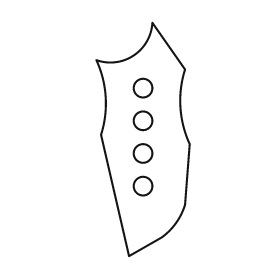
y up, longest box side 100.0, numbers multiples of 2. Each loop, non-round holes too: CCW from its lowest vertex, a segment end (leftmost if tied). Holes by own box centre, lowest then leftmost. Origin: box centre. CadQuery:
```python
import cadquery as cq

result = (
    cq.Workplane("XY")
    .moveTo(-6.0, -50.0)
    .lineTo(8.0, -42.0)
    .threePointArc((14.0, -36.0), (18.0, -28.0))
    .lineTo(20.0, -2.0)
    .threePointArc((16.0, 14.0), (18.0, 30.0))
    .lineTo(4.0, 50.0)
    .threePointArc((-4.0, 36.0), (-20.0, 34.0))
    .threePointArc((-16.0, 18.0), (-18.0, 2.0))
    .close()
    .moveTo(0.0, -20.0)
    .circle(4.0)
    .moveTo(0.0, -6.0)
    .circle(4.0)
    .moveTo(0.0, 8.0)
    .circle(4.0)
    .moveTo(0.0, 22.0)
    .circle(4.0)
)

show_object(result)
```